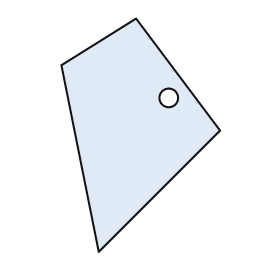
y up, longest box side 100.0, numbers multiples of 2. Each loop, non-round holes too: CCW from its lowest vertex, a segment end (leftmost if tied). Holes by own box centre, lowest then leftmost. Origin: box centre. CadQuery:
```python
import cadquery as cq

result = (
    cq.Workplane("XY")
    .moveTo(-18.0, -50.0)
    .lineTo(34.0, 2.0)
    .lineTo(-2.0, 50.0)
    .lineTo(-34.0, 30.0)
    .close()
    .moveTo(12.0, 16.0)
    .circle(4.0)
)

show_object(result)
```